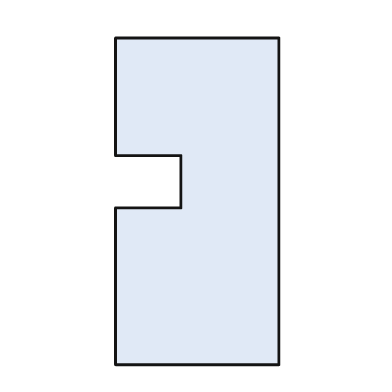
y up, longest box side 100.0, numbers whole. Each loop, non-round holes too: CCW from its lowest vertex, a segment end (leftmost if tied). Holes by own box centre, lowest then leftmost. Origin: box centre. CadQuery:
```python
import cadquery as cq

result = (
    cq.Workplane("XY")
    .moveTo(-25.0, -50.0)
    .lineTo(25.0, -50.0)
    .lineTo(25.0, 50.0)
    .lineTo(-25.0, 50.0)
    .lineTo(-25.0, 14.0)
    .lineTo(-5.0, 14.0)
    .lineTo(-5.0, -2.0)
    .lineTo(-25.0, -2.0)
    .close()
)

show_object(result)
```